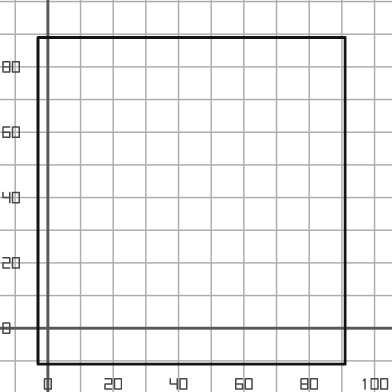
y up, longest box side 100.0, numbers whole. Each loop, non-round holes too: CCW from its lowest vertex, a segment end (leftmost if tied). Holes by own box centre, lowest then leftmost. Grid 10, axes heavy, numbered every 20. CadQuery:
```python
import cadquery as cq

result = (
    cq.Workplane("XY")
    .moveTo(-3.0, -11.0)
    .lineTo(91.0, -11.0)
    .lineTo(91.0, 89.0)
    .lineTo(-3.0, 89.0)
    .close()
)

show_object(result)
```